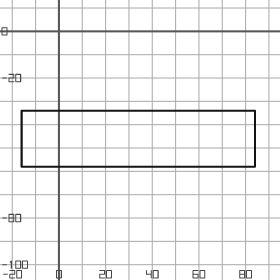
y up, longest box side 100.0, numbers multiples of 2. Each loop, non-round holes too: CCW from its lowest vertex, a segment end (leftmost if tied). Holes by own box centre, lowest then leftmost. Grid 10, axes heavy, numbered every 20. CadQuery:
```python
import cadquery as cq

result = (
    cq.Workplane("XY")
    .moveTo(-16.0, -58.0)
    .lineTo(84.0, -58.0)
    .lineTo(84.0, -34.0)
    .lineTo(-16.0, -34.0)
    .close()
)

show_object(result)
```